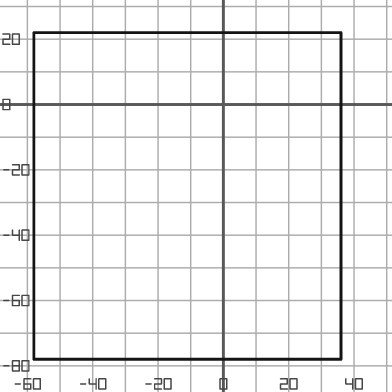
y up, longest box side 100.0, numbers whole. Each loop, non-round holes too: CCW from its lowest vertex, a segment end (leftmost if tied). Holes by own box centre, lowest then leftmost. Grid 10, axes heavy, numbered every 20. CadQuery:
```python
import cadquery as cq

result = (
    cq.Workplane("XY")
    .moveTo(-58.0, -78.0)
    .lineTo(36.0, -78.0)
    .lineTo(36.0, 22.0)
    .lineTo(-58.0, 22.0)
    .close()
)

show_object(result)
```